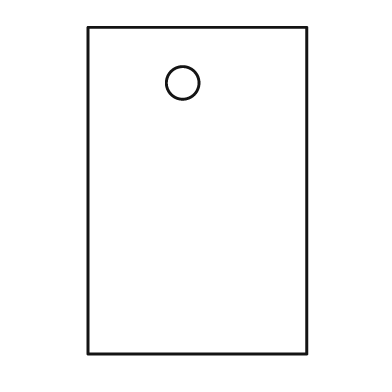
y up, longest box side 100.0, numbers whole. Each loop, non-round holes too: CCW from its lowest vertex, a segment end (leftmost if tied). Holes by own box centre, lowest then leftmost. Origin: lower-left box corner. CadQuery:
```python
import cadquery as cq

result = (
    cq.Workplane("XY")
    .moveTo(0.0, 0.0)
    .lineTo(67.0, 0.0)
    .lineTo(67.0, 100.0)
    .lineTo(0.0, 100.0)
    .close()
    .moveTo(29.0, 83.0)
    .circle(5.0)
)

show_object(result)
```